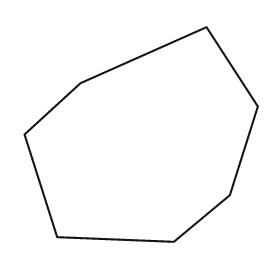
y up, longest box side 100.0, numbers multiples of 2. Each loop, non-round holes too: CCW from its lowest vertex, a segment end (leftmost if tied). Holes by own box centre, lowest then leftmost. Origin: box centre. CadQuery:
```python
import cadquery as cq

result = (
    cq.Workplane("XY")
    .moveTo(14.0, -46.0)
    .lineTo(38.0, -26.0)
    .lineTo(50.0, 12.0)
    .lineTo(28.0, 46.0)
    .lineTo(-26.0, 22.0)
    .lineTo(-50.0, 0.0)
    .lineTo(-36.0, -44.0)
    .close()
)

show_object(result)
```